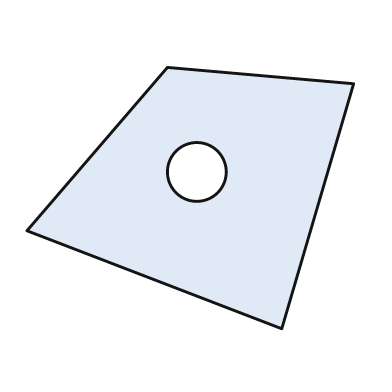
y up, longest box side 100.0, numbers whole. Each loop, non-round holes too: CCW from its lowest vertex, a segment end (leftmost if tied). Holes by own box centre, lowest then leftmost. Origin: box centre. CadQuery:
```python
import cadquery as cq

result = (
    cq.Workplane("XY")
    .moveTo(28.0, -40.0)
    .lineTo(50.0, 35.0)
    .lineTo(-7.0, 40.0)
    .lineTo(-50.0, -10.0)
    .close()
    .moveTo(2.0, 8.0)
    .circle(9.0)
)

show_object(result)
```